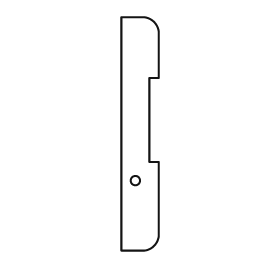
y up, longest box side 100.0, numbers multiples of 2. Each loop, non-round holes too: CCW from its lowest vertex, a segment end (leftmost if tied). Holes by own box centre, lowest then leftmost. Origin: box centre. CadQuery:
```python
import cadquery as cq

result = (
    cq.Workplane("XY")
    .moveTo(-8.0, -50.0)
    .lineTo(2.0, -50.0)
    .threePointArc((6.0, -48.0), (8.0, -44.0))
    .lineTo(8.0, -12.0)
    .lineTo(4.0, -12.0)
    .lineTo(4.0, 24.0)
    .lineTo(8.0, 24.0)
    .lineTo(8.0, 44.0)
    .threePointArc((6.0, 48.0), (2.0, 50.0))
    .lineTo(-8.0, 50.0)
    .close()
    .moveTo(-2.0, -20.0)
    .circle(2.0)
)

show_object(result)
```